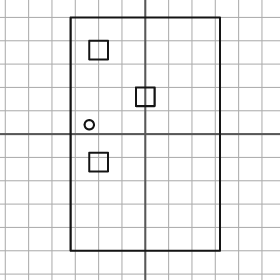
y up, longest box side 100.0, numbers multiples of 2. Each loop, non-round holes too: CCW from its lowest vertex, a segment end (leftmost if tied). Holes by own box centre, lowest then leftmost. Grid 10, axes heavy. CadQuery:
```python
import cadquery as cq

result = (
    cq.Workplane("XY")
    .moveTo(-32.0, -50.0)
    .lineTo(32.0, -50.0)
    .lineTo(32.0, 50.0)
    .lineTo(-32.0, 50.0)
    .close()
    .moveTo(-24.0, -16.0)
    .lineTo(-16.0, -16.0)
    .lineTo(-16.0, -8.0)
    .lineTo(-24.0, -8.0)
    .close()
    .moveTo(-24.0, 4.0)
    .circle(2.0)
    .moveTo(-4.0, 12.0)
    .lineTo(4.0, 12.0)
    .lineTo(4.0, 20.0)
    .lineTo(-4.0, 20.0)
    .close()
    .moveTo(-24.0, 32.0)
    .lineTo(-16.0, 32.0)
    .lineTo(-16.0, 40.0)
    .lineTo(-24.0, 40.0)
    .close()
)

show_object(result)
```